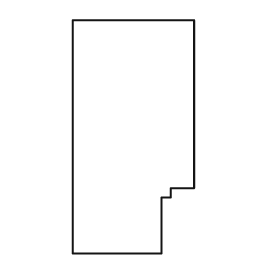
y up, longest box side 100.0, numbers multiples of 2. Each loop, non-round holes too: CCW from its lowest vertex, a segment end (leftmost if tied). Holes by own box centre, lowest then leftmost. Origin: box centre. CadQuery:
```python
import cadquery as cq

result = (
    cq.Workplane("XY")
    .moveTo(-26.0, -50.0)
    .lineTo(12.0, -50.0)
    .lineTo(12.0, -26.0)
    .lineTo(16.0, -26.0)
    .lineTo(16.0, -22.0)
    .lineTo(26.0, -22.0)
    .lineTo(26.0, 50.0)
    .lineTo(-26.0, 50.0)
    .close()
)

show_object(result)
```